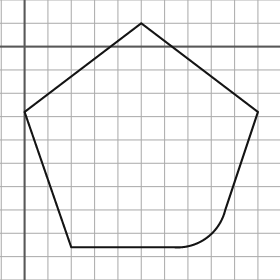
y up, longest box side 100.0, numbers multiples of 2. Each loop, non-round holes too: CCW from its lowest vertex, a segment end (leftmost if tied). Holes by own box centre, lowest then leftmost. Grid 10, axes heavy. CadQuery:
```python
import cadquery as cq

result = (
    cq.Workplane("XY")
    .moveTo(20.0, -86.0)
    .lineTo(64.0, -86.0)
    .threePointArc((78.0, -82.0), (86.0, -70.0))
    .lineTo(100.0, -28.0)
    .lineTo(50.0, 10.0)
    .lineTo(0.0, -28.0)
    .close()
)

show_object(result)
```